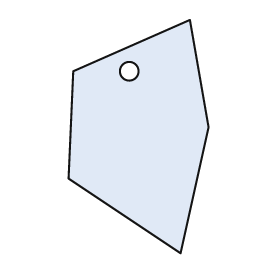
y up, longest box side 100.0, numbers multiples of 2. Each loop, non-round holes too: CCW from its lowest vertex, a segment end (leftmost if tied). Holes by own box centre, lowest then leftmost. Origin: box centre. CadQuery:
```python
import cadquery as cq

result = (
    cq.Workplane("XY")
    .moveTo(18.0, -50.0)
    .lineTo(30.0, 4.0)
    .lineTo(22.0, 50.0)
    .lineTo(-28.0, 28.0)
    .lineTo(-30.0, -18.0)
    .close()
    .moveTo(-4.0, 28.0)
    .circle(4.0)
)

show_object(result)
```